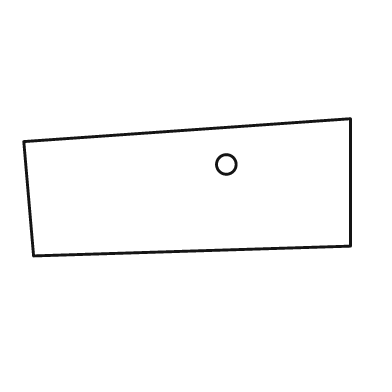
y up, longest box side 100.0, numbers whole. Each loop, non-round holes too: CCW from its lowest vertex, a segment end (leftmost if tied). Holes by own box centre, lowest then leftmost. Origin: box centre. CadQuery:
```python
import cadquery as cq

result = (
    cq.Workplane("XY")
    .moveTo(-47.0, -21.0)
    .lineTo(50.0, -18.0)
    .lineTo(50.0, 21.0)
    .lineTo(-50.0, 14.0)
    .close()
    .moveTo(12.0, 7.0)
    .circle(3.0)
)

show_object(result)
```